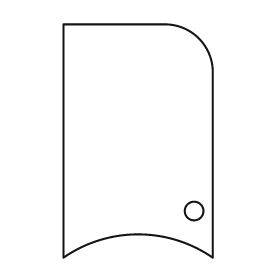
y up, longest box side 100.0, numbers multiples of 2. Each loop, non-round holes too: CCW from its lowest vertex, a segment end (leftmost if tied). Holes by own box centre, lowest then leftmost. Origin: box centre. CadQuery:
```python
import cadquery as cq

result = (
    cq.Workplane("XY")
    .moveTo(-32.0, -50.0)
    .threePointArc((0.0, -40.0), (32.0, -50.0))
    .lineTo(32.0, 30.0)
    .threePointArc((26.0, 44.0), (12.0, 50.0))
    .lineTo(-32.0, 50.0)
    .close()
    .moveTo(24.0, -30.0)
    .circle(4.0)
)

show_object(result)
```